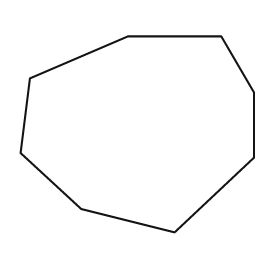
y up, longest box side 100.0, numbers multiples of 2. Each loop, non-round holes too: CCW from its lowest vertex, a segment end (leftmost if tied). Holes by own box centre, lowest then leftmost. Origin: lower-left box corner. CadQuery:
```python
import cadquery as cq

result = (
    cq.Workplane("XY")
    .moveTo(66.0, 0.0)
    .lineTo(100.0, 32.0)
    .lineTo(100.0, 60.0)
    .lineTo(86.0, 84.0)
    .lineTo(46.0, 84.0)
    .lineTo(4.0, 66.0)
    .lineTo(0.0, 34.0)
    .lineTo(26.0, 10.0)
    .close()
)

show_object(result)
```